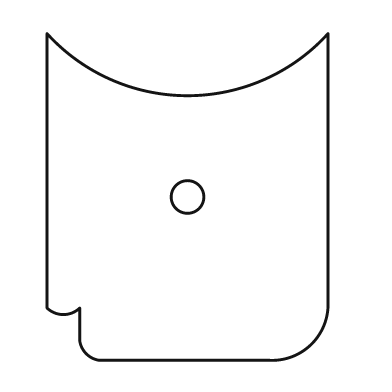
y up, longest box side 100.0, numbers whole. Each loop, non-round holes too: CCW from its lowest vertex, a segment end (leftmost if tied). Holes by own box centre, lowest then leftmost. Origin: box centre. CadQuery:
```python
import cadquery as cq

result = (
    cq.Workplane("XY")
    .moveTo(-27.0, -50.0)
    .lineTo(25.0, -50.0)
    .threePointArc((38.0, -45.0), (43.0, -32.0))
    .lineTo(43.0, 50.0)
    .threePointArc((0.0, 31.0), (-43.0, 50.0))
    .lineTo(-43.0, -34.0)
    .threePointArc((-38.0, -36.0), (-33.0, -34.0))
    .lineTo(-33.0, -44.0)
    .threePointArc((-31.0, -48.0), (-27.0, -50.0))
    .close()
    .moveTo(0.0, 0.0)
    .circle(5.0)
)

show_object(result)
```